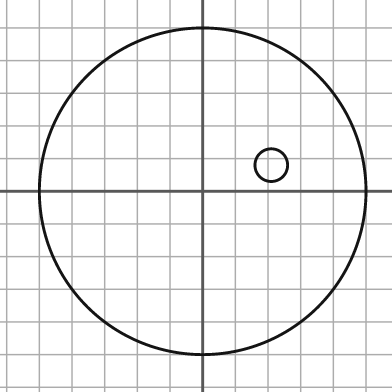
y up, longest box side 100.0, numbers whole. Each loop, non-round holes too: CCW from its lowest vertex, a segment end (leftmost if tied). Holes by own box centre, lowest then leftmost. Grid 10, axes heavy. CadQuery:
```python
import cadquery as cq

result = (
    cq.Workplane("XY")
    .moveTo(0.0, 0.0)
    .circle(50.0)
    .moveTo(21.0, 8.0)
    .circle(5.0)
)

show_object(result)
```